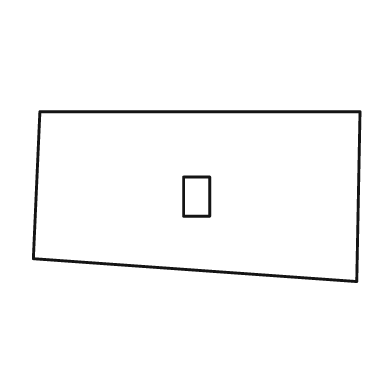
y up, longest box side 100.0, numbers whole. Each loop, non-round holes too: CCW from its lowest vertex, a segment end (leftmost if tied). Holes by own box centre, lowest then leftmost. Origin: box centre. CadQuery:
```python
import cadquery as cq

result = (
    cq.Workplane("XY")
    .moveTo(49.0, -26.0)
    .lineTo(50.0, 26.0)
    .lineTo(-48.0, 26.0)
    .lineTo(-50.0, -19.0)
    .close()
    .moveTo(-4.0, -6.0)
    .lineTo(4.0, -6.0)
    .lineTo(4.0, 6.0)
    .lineTo(-4.0, 6.0)
    .close()
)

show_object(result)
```